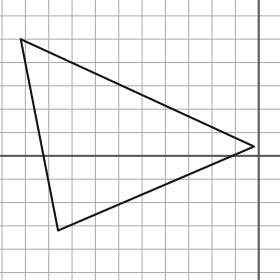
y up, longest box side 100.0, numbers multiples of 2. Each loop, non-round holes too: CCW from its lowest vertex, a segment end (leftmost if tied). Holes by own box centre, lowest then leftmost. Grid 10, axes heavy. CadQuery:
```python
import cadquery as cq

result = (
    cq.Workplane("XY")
    .moveTo(-86.0, -32.0)
    .lineTo(-2.0, 4.0)
    .lineTo(-102.0, 50.0)
    .close()
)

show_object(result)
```